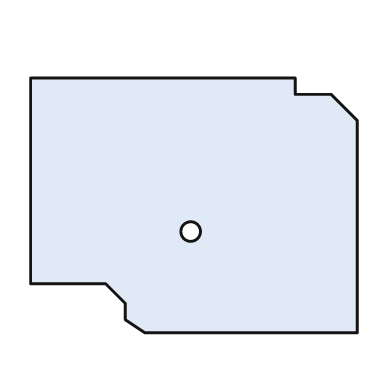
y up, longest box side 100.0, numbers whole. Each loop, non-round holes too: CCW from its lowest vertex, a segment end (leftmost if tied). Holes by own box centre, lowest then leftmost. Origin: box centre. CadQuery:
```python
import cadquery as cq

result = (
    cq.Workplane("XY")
    .moveTo(-15.0, -39.0)
    .lineTo(50.0, -39.0)
    .lineTo(50.0, 26.0)
    .lineTo(42.0, 34.0)
    .lineTo(31.0, 34.0)
    .lineTo(31.0, 39.0)
    .lineTo(-50.0, 39.0)
    .lineTo(-50.0, -24.0)
    .lineTo(-27.0, -24.0)
    .lineTo(-21.0, -30.0)
    .lineTo(-21.0, -35.0)
    .close()
    .moveTo(-1.0, -8.0)
    .circle(3.0)
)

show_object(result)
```